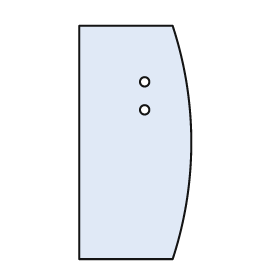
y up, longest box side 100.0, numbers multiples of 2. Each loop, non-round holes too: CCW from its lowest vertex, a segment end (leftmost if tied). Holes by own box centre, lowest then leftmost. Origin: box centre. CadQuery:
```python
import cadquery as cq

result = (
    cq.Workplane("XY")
    .moveTo(-24.0, -50.0)
    .lineTo(16.0, -50.0)
    .threePointArc((24.0, 0.0), (16.0, 50.0))
    .lineTo(-24.0, 50.0)
    .close()
    .moveTo(4.0, 14.0)
    .circle(2.0)
    .moveTo(4.0, 26.0)
    .circle(2.0)
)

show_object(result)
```